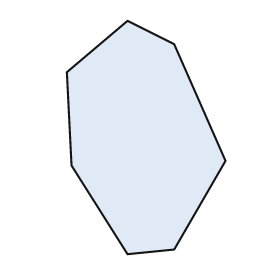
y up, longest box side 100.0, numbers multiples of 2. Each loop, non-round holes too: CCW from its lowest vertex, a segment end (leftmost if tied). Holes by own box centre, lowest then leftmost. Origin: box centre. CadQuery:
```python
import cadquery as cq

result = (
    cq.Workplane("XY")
    .moveTo(-8.0, -50.0)
    .lineTo(12.0, -48.0)
    .lineTo(34.0, -10.0)
    .lineTo(12.0, 40.0)
    .lineTo(-8.0, 50.0)
    .lineTo(-34.0, 28.0)
    .lineTo(-32.0, -12.0)
    .close()
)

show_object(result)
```